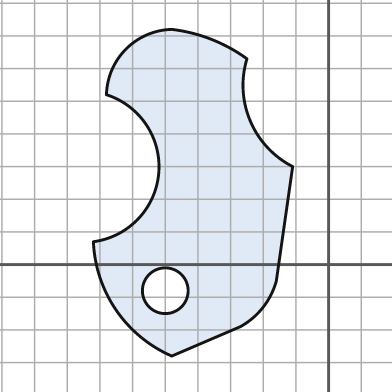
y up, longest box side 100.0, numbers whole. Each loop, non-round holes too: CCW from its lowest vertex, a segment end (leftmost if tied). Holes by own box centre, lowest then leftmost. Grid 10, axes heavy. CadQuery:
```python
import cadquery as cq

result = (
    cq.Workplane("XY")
    .moveTo(-48.0, -28.0)
    .lineTo(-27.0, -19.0)
    .threePointArc((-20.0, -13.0), (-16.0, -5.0))
    .lineTo(-11.0, 30.0)
    .threePointArc((-24.0, 44.0), (-25.0, 63.0))
    .threePointArc((-36.0, 69.0), (-48.0, 72.0))
    .threePointArc((-62.0, 66.0), (-68.0, 52.0))
    .threePointArc((-52.0, 28.0), (-72.0, 7.0))
    .threePointArc((-65.0, -14.0), (-48.0, -28.0))
    .close()
    .moveTo(-50.0, -8.0)
    .circle(7.0)
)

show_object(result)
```